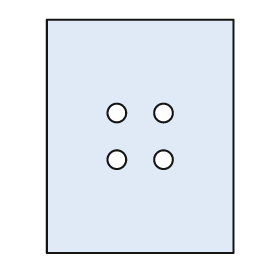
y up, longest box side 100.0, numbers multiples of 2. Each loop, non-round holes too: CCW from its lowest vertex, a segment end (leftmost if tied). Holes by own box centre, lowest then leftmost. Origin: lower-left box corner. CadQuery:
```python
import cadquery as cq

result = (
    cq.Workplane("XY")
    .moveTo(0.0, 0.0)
    .lineTo(80.0, 0.0)
    .lineTo(80.0, 100.0)
    .lineTo(0.0, 100.0)
    .close()
    .moveTo(30.0, 40.0)
    .circle(4.0)
    .moveTo(50.0, 40.0)
    .circle(4.0)
    .moveTo(30.0, 60.0)
    .circle(4.0)
    .moveTo(50.0, 60.0)
    .circle(4.0)
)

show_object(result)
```